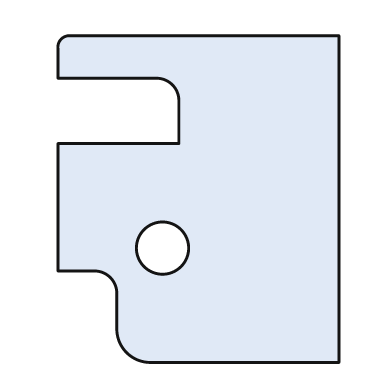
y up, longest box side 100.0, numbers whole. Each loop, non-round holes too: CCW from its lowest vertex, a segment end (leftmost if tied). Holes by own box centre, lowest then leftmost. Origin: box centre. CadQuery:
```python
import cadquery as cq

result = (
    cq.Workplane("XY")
    .moveTo(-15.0, -50.0)
    .lineTo(43.0, -50.0)
    .lineTo(43.0, 50.0)
    .lineTo(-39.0, 50.0)
    .threePointArc((-42.0, 49.0), (-43.0, 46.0))
    .lineTo(-43.0, 37.0)
    .lineTo(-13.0, 37.0)
    .threePointArc((-8.0, 35.0), (-6.0, 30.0))
    .lineTo(-6.0, 17.0)
    .lineTo(-43.0, 17.0)
    .lineTo(-43.0, -22.0)
    .lineTo(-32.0, -22.0)
    .threePointArc((-27.0, -24.0), (-25.0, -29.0))
    .lineTo(-25.0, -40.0)
    .threePointArc((-22.0, -47.0), (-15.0, -50.0))
    .close()
    .moveTo(-11.0, -15.0)
    .circle(8.0)
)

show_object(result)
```